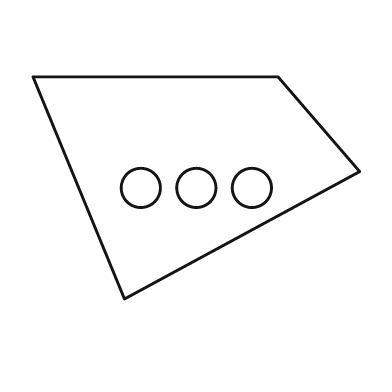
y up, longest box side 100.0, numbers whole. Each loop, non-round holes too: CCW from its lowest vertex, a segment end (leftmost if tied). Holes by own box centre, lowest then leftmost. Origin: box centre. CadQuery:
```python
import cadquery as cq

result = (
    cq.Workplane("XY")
    .moveTo(-22.0, -34.0)
    .lineTo(50.0, 5.0)
    .lineTo(25.0, 34.0)
    .lineTo(-50.0, 34.0)
    .close()
    .moveTo(-17.0, 0.0)
    .circle(6.0)
    .moveTo(0.0, 0.0)
    .circle(6.0)
    .moveTo(17.0, 0.0)
    .circle(6.0)
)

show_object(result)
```